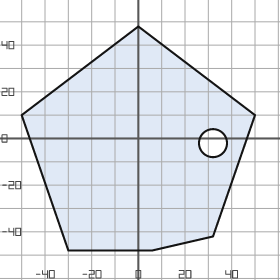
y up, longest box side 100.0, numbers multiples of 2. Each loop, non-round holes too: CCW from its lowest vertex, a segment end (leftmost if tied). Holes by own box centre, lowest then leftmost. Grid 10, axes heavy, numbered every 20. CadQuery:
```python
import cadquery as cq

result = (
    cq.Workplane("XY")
    .moveTo(-30.0, -48.0)
    .lineTo(6.0, -48.0)
    .lineTo(32.0, -42.0)
    .lineTo(50.0, 10.0)
    .lineTo(0.0, 48.0)
    .lineTo(-50.0, 10.0)
    .close()
    .moveTo(32.0, -2.0)
    .circle(6.0)
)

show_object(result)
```